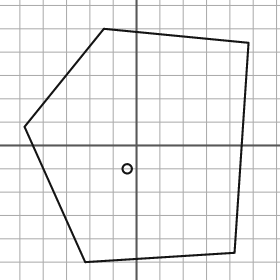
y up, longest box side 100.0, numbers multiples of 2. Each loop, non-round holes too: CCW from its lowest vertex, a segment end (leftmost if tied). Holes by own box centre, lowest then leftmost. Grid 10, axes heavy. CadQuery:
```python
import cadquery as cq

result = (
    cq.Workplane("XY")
    .moveTo(-22.0, -50.0)
    .lineTo(42.0, -46.0)
    .lineTo(48.0, 44.0)
    .lineTo(-14.0, 50.0)
    .lineTo(-48.0, 8.0)
    .close()
    .moveTo(-4.0, -10.0)
    .circle(2.0)
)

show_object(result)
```